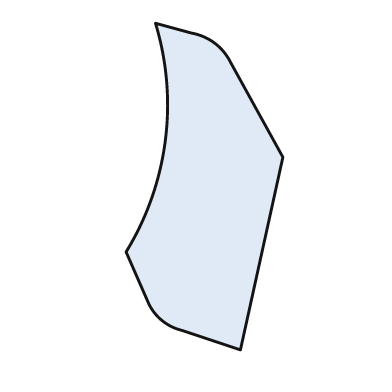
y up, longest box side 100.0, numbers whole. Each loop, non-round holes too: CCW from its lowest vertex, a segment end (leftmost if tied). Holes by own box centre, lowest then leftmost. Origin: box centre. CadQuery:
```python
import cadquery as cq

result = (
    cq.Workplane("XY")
    .moveTo(11.0, -50.0)
    .lineTo(24.0, 9.0)
    .lineTo(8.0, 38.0)
    .threePointArc((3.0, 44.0), (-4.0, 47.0))
    .lineTo(-15.0, 50.0)
    .threePointArc((-12.0, 14.0), (-24.0, -20.0))
    .lineTo(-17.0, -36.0)
    .threePointArc((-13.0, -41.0), (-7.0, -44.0))
    .close()
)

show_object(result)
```